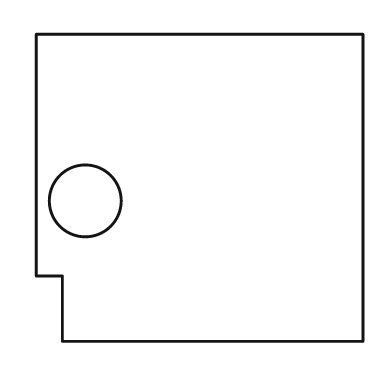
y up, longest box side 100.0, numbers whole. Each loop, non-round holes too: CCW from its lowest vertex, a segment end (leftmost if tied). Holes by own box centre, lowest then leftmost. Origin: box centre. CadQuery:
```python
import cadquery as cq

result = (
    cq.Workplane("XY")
    .moveTo(-42.0, -47.0)
    .lineTo(50.0, -47.0)
    .lineTo(50.0, 47.0)
    .lineTo(-50.0, 47.0)
    .lineTo(-50.0, -27.0)
    .lineTo(-42.0, -27.0)
    .close()
    .moveTo(-35.0, -4.0)
    .circle(11.0)
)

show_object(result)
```